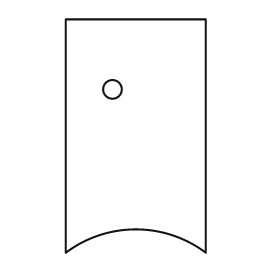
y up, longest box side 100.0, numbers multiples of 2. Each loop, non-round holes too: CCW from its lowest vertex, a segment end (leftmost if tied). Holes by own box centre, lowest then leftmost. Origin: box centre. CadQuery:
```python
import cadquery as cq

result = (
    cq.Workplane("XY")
    .moveTo(-30.0, -50.0)
    .threePointArc((0.0, -40.0), (30.0, -50.0))
    .lineTo(30.0, 50.0)
    .lineTo(-30.0, 50.0)
    .close()
    .moveTo(-10.0, 20.0)
    .circle(4.0)
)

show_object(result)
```